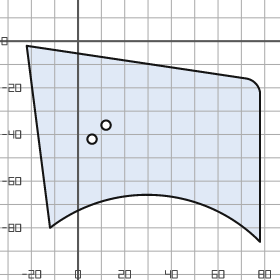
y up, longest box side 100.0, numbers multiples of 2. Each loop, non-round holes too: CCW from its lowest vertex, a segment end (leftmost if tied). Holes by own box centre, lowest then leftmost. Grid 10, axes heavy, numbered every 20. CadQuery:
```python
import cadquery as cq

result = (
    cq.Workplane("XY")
    .moveTo(78.0, -86.0)
    .lineTo(78.0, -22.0)
    .threePointArc((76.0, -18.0), (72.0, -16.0))
    .lineTo(-22.0, -2.0)
    .lineTo(-12.0, -80.0)
    .threePointArc((34.0, -66.0), (78.0, -86.0))
    .close()
    .moveTo(6.0, -42.0)
    .circle(2.0)
    .moveTo(12.0, -36.0)
    .circle(2.0)
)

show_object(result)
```